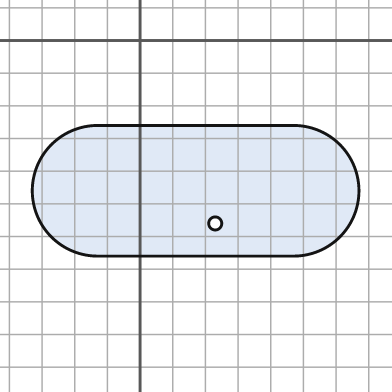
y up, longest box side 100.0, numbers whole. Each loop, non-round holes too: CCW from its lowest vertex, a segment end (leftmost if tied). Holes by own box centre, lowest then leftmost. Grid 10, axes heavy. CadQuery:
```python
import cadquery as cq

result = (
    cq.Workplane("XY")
    .moveTo(-13.0, -66.0)
    .lineTo(47.0, -66.0)
    .threePointArc((67.0, -46.0), (47.0, -26.0))
    .lineTo(-13.0, -26.0)
    .threePointArc((-33.0, -46.0), (-13.0, -66.0))
    .close()
    .moveTo(23.0, -56.0)
    .circle(2.0)
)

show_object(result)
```